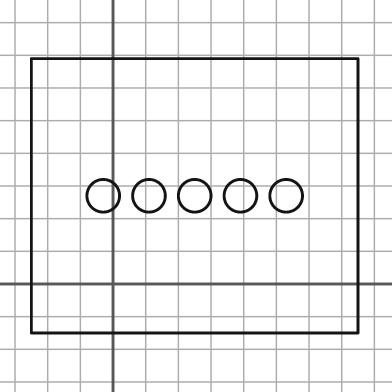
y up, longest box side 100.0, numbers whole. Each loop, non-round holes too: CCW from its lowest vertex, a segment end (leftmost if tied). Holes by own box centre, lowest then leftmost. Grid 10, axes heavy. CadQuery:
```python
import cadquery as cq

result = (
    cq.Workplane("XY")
    .moveTo(-25.0, -15.0)
    .lineTo(75.0, -15.0)
    .lineTo(75.0, 69.0)
    .lineTo(-25.0, 69.0)
    .close()
    .moveTo(-3.0, 27.0)
    .circle(5.0)
    .moveTo(11.0, 27.0)
    .circle(5.0)
    .moveTo(25.0, 27.0)
    .circle(5.0)
    .moveTo(39.0, 27.0)
    .circle(5.0)
    .moveTo(53.0, 27.0)
    .circle(5.0)
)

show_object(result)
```